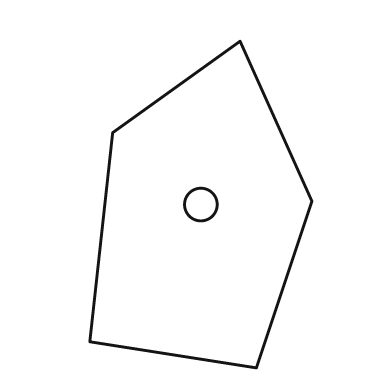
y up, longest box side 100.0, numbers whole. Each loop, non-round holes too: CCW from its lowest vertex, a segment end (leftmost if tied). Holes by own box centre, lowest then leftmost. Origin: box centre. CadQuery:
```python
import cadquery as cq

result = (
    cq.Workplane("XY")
    .moveTo(17.0, -50.0)
    .lineTo(34.0, 1.0)
    .lineTo(12.0, 50.0)
    .lineTo(-27.0, 22.0)
    .lineTo(-34.0, -42.0)
    .close()
    .moveTo(0.0, 0.0)
    .circle(5.0)
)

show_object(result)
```